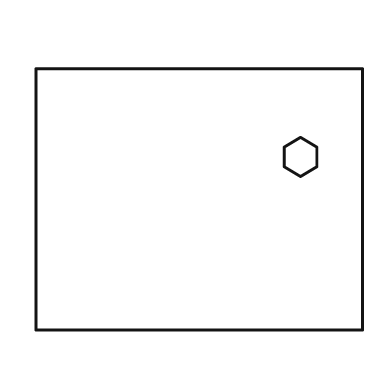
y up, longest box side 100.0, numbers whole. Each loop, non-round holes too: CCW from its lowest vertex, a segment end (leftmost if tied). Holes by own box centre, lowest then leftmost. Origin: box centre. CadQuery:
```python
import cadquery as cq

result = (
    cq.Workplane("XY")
    .moveTo(-50.0, -40.0)
    .lineTo(50.0, -40.0)
    .lineTo(50.0, 40.0)
    .lineTo(-50.0, 40.0)
    .close()
    .moveTo(31.0, 7.0)
    .lineTo(36.0, 10.0)
    .lineTo(36.0, 16.0)
    .lineTo(31.0, 19.0)
    .lineTo(26.0, 16.0)
    .lineTo(26.0, 10.0)
    .close()
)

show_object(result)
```